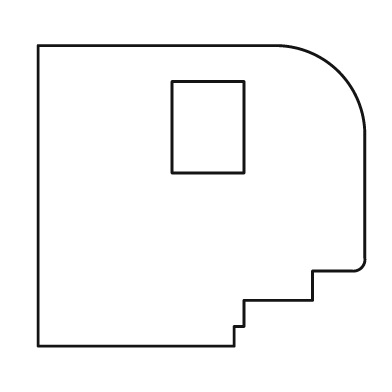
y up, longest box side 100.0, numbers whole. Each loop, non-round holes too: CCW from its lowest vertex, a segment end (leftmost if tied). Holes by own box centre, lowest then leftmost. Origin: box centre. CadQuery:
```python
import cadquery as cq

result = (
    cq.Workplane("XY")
    .moveTo(-50.0, -46.0)
    .lineTo(10.0, -46.0)
    .lineTo(10.0, -40.0)
    .lineTo(13.0, -40.0)
    .lineTo(13.0, -32.0)
    .lineTo(34.0, -32.0)
    .lineTo(34.0, -23.0)
    .lineTo(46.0, -23.0)
    .threePointArc((49.0, -22.0), (50.0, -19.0))
    .lineTo(50.0, 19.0)
    .threePointArc((42.0, 38.0), (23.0, 46.0))
    .lineTo(-50.0, 46.0)
    .close()
    .moveTo(-9.0, 7.0)
    .lineTo(13.0, 7.0)
    .lineTo(13.0, 35.0)
    .lineTo(-9.0, 35.0)
    .close()
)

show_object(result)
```